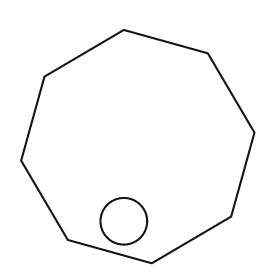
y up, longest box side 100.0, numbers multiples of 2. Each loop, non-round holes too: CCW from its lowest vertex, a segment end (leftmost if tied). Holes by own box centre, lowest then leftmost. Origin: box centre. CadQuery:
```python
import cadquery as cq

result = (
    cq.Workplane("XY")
    .moveTo(6.0, -50.0)
    .lineTo(40.0, -30.0)
    .lineTo(50.0, 6.0)
    .lineTo(30.0, 40.0)
    .lineTo(-6.0, 50.0)
    .lineTo(-40.0, 30.0)
    .lineTo(-50.0, -6.0)
    .lineTo(-30.0, -40.0)
    .close()
    .moveTo(-6.0, -32.0)
    .circle(10.0)
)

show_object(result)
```